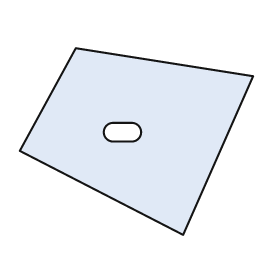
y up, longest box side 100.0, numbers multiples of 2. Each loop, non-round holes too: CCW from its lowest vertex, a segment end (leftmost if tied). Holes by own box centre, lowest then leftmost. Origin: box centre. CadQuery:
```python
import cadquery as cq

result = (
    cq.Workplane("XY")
    .moveTo(20.0, -40.0)
    .lineTo(50.0, 28.0)
    .lineTo(-26.0, 40.0)
    .lineTo(-50.0, -4.0)
    .close()
    .moveTo(-10.0, 0.0)
    .lineTo(-2.0, 0.0)
    .threePointArc((2.0, 4.0), (-2.0, 8.0))
    .lineTo(-10.0, 8.0)
    .threePointArc((-14.0, 4.0), (-10.0, 0.0))
    .close()
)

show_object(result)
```